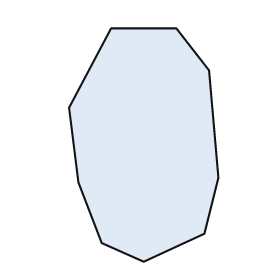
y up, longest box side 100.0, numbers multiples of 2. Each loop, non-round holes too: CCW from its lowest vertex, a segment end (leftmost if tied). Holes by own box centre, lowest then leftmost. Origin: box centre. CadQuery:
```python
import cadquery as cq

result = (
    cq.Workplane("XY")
    .moveTo(0.0, -50.0)
    .lineTo(26.0, -38.0)
    .lineTo(32.0, -14.0)
    .lineTo(28.0, 32.0)
    .lineTo(14.0, 50.0)
    .lineTo(-14.0, 50.0)
    .lineTo(-32.0, 16.0)
    .lineTo(-28.0, -16.0)
    .lineTo(-18.0, -42.0)
    .close()
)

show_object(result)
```